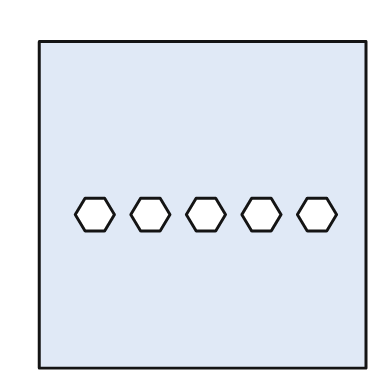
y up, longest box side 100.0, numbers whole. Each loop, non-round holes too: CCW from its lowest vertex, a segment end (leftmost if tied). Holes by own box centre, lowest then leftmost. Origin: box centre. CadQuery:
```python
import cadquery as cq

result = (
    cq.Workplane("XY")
    .moveTo(-50.0, -50.0)
    .lineTo(50.0, -50.0)
    .lineTo(50.0, 50.0)
    .lineTo(-50.0, 50.0)
    .close()
    .moveTo(-36.0, -8.0)
    .lineTo(-30.0, -8.0)
    .lineTo(-27.0, -3.0)
    .lineTo(-30.0, 2.0)
    .lineTo(-36.0, 2.0)
    .lineTo(-39.0, -3.0)
    .close()
    .moveTo(-19.0, -8.0)
    .lineTo(-13.0, -8.0)
    .lineTo(-10.0, -3.0)
    .lineTo(-13.0, 2.0)
    .lineTo(-19.0, 2.0)
    .lineTo(-22.0, -3.0)
    .close()
    .moveTo(-2.0, -8.0)
    .lineTo(4.0, -8.0)
    .lineTo(7.0, -3.0)
    .lineTo(4.0, 2.0)
    .lineTo(-2.0, 2.0)
    .lineTo(-5.0, -3.0)
    .close()
    .moveTo(15.0, -8.0)
    .lineTo(21.0, -8.0)
    .lineTo(24.0, -3.0)
    .lineTo(21.0, 2.0)
    .lineTo(15.0, 2.0)
    .lineTo(12.0, -3.0)
    .close()
    .moveTo(32.0, -8.0)
    .lineTo(38.0, -8.0)
    .lineTo(41.0, -3.0)
    .lineTo(38.0, 2.0)
    .lineTo(32.0, 2.0)
    .lineTo(29.0, -3.0)
    .close()
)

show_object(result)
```